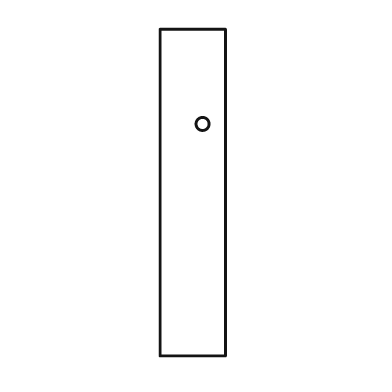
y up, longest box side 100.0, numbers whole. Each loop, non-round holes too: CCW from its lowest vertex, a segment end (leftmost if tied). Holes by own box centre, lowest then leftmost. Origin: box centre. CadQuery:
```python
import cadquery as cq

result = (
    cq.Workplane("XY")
    .moveTo(-10.0, -50.0)
    .lineTo(10.0, -50.0)
    .lineTo(10.0, 50.0)
    .lineTo(-10.0, 50.0)
    .close()
    .moveTo(3.0, 21.0)
    .circle(2.0)
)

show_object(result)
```